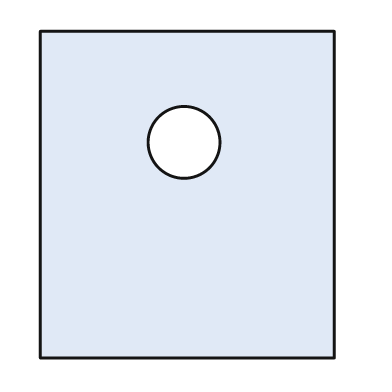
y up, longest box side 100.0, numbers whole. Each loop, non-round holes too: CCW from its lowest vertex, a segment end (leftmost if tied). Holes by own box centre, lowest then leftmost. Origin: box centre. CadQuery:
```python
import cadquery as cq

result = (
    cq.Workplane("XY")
    .moveTo(-45.0, -50.0)
    .lineTo(45.0, -50.0)
    .lineTo(45.0, 50.0)
    .lineTo(-45.0, 50.0)
    .close()
    .moveTo(-1.0, 16.0)
    .circle(11.0)
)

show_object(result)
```